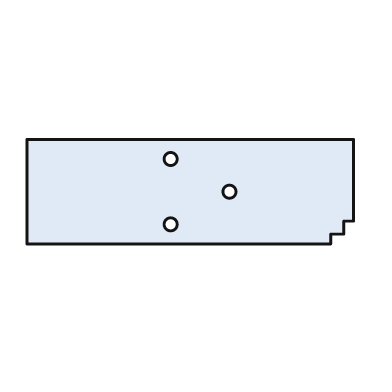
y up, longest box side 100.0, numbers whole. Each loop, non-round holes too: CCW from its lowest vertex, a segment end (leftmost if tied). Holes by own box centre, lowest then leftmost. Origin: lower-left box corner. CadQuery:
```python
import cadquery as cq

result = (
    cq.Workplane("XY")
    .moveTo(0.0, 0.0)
    .lineTo(93.0, 0.0)
    .lineTo(93.0, 3.0)
    .lineTo(97.0, 3.0)
    .lineTo(97.0, 7.0)
    .lineTo(100.0, 7.0)
    .lineTo(100.0, 32.0)
    .lineTo(0.0, 32.0)
    .close()
    .moveTo(44.0, 6.0)
    .circle(2.0)
    .moveTo(62.0, 16.0)
    .circle(2.0)
    .moveTo(44.0, 26.0)
    .circle(2.0)
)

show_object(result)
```